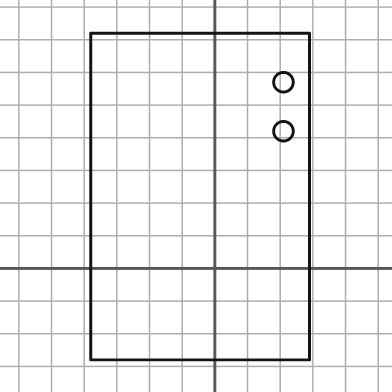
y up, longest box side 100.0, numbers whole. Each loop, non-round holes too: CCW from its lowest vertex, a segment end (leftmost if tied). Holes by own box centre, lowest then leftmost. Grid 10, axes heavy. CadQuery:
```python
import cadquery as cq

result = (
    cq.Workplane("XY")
    .moveTo(-38.0, -28.0)
    .lineTo(29.0, -28.0)
    .lineTo(29.0, 72.0)
    .lineTo(-38.0, 72.0)
    .close()
    .moveTo(21.0, 42.0)
    .circle(3.0)
    .moveTo(21.0, 57.0)
    .circle(3.0)
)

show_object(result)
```